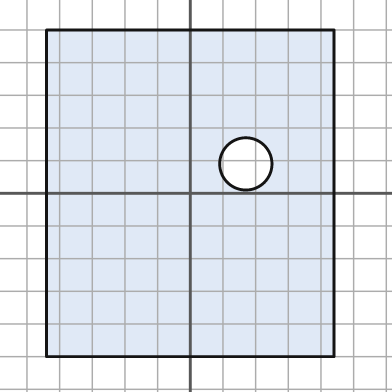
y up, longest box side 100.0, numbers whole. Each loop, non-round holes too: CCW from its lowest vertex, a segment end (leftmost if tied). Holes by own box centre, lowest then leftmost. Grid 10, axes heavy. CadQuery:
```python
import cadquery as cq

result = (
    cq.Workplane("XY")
    .moveTo(-44.0, -50.0)
    .lineTo(44.0, -50.0)
    .lineTo(44.0, 50.0)
    .lineTo(-44.0, 50.0)
    .close()
    .moveTo(17.0, 9.0)
    .circle(8.0)
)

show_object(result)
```